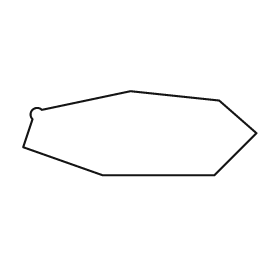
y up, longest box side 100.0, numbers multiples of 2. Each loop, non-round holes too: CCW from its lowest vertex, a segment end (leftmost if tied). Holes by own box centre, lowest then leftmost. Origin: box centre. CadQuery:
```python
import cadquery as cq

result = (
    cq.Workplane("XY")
    .moveTo(-16.0, -18.0)
    .lineTo(32.0, -18.0)
    .lineTo(50.0, 0.0)
    .lineTo(34.0, 14.0)
    .lineTo(-4.0, 18.0)
    .lineTo(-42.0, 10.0)
    .threePointArc((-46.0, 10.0), (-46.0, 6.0))
    .lineTo(-50.0, -6.0)
    .close()
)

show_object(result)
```